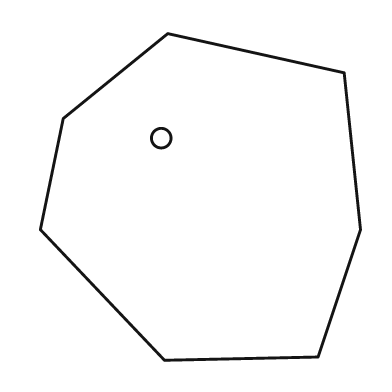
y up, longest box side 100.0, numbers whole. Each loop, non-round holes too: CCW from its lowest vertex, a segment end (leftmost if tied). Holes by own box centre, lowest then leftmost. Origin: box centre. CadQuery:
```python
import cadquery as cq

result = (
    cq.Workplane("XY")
    .moveTo(-11.0, -50.0)
    .lineTo(36.0, -49.0)
    .lineTo(49.0, -10.0)
    .lineTo(44.0, 38.0)
    .lineTo(-10.0, 50.0)
    .lineTo(-42.0, 24.0)
    .lineTo(-49.0, -10.0)
    .close()
    .moveTo(-12.0, 18.0)
    .circle(3.0)
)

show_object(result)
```